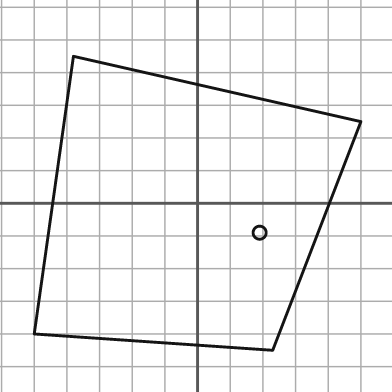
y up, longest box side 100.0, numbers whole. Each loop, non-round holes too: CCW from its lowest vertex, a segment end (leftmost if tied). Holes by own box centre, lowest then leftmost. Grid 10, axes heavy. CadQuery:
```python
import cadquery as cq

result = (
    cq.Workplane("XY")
    .moveTo(23.0, -45.0)
    .lineTo(50.0, 25.0)
    .lineTo(-38.0, 45.0)
    .lineTo(-50.0, -40.0)
    .close()
    .moveTo(19.0, -9.0)
    .circle(2.0)
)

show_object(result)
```